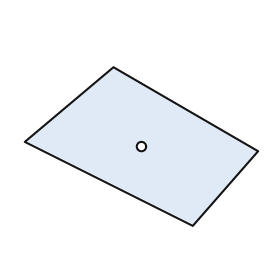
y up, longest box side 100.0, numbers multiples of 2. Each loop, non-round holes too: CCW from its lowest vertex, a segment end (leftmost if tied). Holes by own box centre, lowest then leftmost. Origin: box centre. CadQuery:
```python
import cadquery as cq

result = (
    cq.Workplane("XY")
    .moveTo(22.0, -34.0)
    .lineTo(50.0, -2.0)
    .lineTo(-12.0, 34.0)
    .lineTo(-50.0, 2.0)
    .close()
    .moveTo(0.0, 0.0)
    .circle(2.0)
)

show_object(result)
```